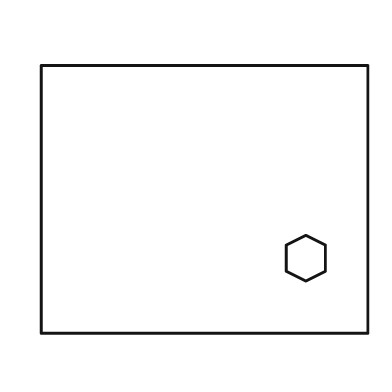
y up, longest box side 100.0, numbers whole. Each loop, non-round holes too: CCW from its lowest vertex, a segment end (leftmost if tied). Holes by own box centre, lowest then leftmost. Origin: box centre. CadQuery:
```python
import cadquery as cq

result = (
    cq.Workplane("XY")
    .moveTo(-50.0, -41.0)
    .lineTo(50.0, -41.0)
    .lineTo(50.0, 41.0)
    .lineTo(-50.0, 41.0)
    .close()
    .moveTo(31.0, -25.0)
    .lineTo(37.0, -22.0)
    .lineTo(37.0, -14.0)
    .lineTo(31.0, -11.0)
    .lineTo(25.0, -14.0)
    .lineTo(25.0, -22.0)
    .close()
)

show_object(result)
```